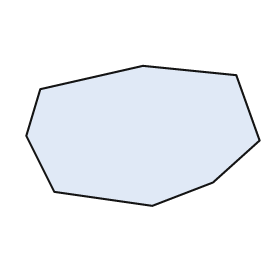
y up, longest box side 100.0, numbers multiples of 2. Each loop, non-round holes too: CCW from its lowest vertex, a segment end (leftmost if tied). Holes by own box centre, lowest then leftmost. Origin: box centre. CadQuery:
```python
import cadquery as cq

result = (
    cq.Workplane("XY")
    .moveTo(4.0, -30.0)
    .lineTo(30.0, -20.0)
    .lineTo(50.0, -2.0)
    .lineTo(40.0, 26.0)
    .lineTo(0.0, 30.0)
    .lineTo(-44.0, 20.0)
    .lineTo(-50.0, 0.0)
    .lineTo(-38.0, -24.0)
    .close()
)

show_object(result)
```